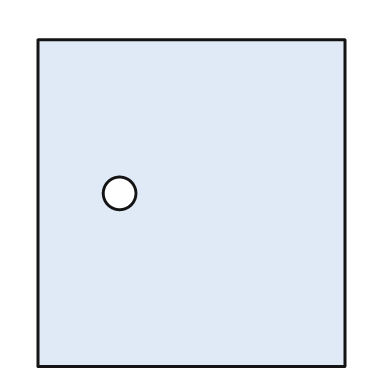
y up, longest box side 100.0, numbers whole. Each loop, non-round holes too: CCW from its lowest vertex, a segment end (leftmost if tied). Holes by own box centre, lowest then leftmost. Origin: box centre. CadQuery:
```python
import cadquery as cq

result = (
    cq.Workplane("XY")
    .moveTo(-47.0, -50.0)
    .lineTo(47.0, -50.0)
    .lineTo(47.0, 50.0)
    .lineTo(-47.0, 50.0)
    .close()
    .moveTo(-22.0, 3.0)
    .circle(5.0)
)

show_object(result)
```